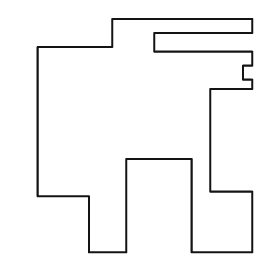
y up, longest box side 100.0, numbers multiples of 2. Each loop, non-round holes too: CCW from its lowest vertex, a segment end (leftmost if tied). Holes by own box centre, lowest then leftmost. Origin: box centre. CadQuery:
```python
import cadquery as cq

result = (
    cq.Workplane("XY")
    .moveTo(-24.0, -50.0)
    .lineTo(-8.0, -50.0)
    .lineTo(-8.0, -10.0)
    .lineTo(20.0, -10.0)
    .lineTo(20.0, -50.0)
    .lineTo(46.0, -50.0)
    .lineTo(46.0, -24.0)
    .lineTo(28.0, -24.0)
    .lineTo(28.0, 20.0)
    .lineTo(46.0, 20.0)
    .lineTo(46.0, 24.0)
    .lineTo(42.0, 24.0)
    .lineTo(42.0, 30.0)
    .lineTo(46.0, 30.0)
    .lineTo(46.0, 36.0)
    .lineTo(4.0, 36.0)
    .lineTo(4.0, 44.0)
    .lineTo(46.0, 44.0)
    .lineTo(46.0, 50.0)
    .lineTo(-14.0, 50.0)
    .lineTo(-14.0, 38.0)
    .lineTo(-46.0, 38.0)
    .lineTo(-46.0, -26.0)
    .lineTo(-24.0, -26.0)
    .close()
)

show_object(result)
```